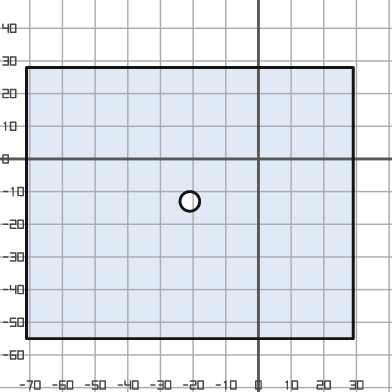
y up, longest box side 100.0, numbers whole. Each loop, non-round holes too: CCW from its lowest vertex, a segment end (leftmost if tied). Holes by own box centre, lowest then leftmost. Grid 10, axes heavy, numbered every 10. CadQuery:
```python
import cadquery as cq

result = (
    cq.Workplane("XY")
    .moveTo(-71.0, -55.0)
    .lineTo(29.0, -55.0)
    .lineTo(29.0, 28.0)
    .lineTo(-71.0, 28.0)
    .close()
    .moveTo(-21.0, -13.0)
    .circle(3.0)
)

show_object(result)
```